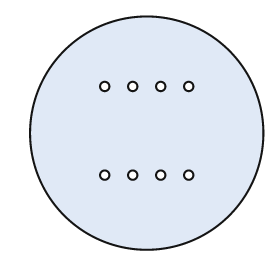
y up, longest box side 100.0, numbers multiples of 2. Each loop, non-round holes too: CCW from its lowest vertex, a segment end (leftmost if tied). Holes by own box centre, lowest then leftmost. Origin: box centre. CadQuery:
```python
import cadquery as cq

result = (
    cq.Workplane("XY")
    .moveTo(0.0, 0.0)
    .circle(50.0)
    .moveTo(-18.0, -18.0)
    .circle(2.0)
    .moveTo(-6.0, -18.0)
    .circle(2.0)
    .moveTo(6.0, -18.0)
    .circle(2.0)
    .moveTo(18.0, -18.0)
    .circle(2.0)
    .moveTo(-18.0, 20.0)
    .circle(2.0)
    .moveTo(-6.0, 20.0)
    .circle(2.0)
    .moveTo(6.0, 20.0)
    .circle(2.0)
    .moveTo(18.0, 20.0)
    .circle(2.0)
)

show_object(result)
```